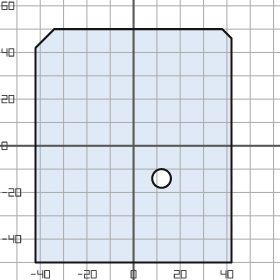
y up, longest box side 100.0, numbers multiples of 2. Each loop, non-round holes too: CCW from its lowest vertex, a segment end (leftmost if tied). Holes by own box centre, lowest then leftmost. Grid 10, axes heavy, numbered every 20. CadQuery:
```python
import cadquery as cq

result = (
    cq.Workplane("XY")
    .moveTo(-42.0, -50.0)
    .lineTo(42.0, -50.0)
    .lineTo(42.0, 46.0)
    .lineTo(38.0, 50.0)
    .lineTo(-34.0, 50.0)
    .lineTo(-42.0, 42.0)
    .close()
    .moveTo(12.0, -14.0)
    .circle(4.0)
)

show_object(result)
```